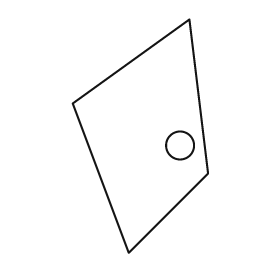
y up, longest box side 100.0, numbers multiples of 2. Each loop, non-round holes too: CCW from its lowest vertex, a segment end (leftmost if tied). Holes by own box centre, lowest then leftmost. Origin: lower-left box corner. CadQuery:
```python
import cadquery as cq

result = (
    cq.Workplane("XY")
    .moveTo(24.0, 0.0)
    .lineTo(58.0, 34.0)
    .lineTo(50.0, 100.0)
    .lineTo(0.0, 64.0)
    .close()
    .moveTo(46.0, 46.0)
    .circle(6.0)
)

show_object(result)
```